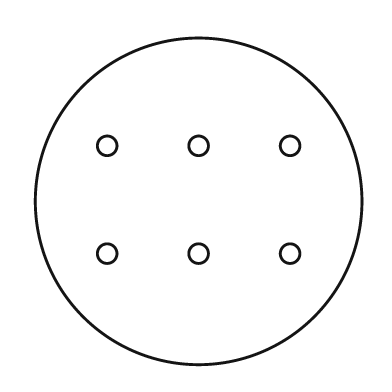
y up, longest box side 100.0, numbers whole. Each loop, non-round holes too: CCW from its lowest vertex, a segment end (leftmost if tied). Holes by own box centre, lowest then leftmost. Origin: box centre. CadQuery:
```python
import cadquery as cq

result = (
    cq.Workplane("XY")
    .moveTo(0.0, 0.0)
    .circle(50.0)
    .moveTo(-28.0, -16.0)
    .circle(3.0)
    .moveTo(0.0, -16.0)
    .circle(3.0)
    .moveTo(28.0, -16.0)
    .circle(3.0)
    .moveTo(-28.0, 17.0)
    .circle(3.0)
    .moveTo(0.0, 17.0)
    .circle(3.0)
    .moveTo(28.0, 17.0)
    .circle(3.0)
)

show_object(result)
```